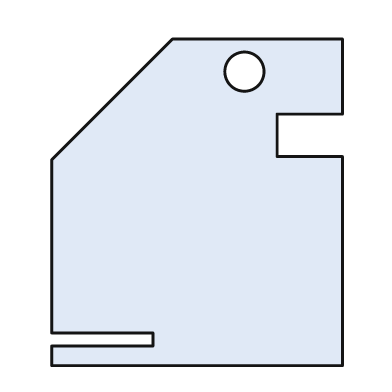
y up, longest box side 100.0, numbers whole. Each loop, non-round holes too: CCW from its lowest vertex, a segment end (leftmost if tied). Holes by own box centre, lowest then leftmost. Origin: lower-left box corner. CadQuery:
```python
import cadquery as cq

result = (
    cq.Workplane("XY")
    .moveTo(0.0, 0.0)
    .lineTo(89.0, 0.0)
    .lineTo(89.0, 64.0)
    .lineTo(69.0, 64.0)
    .lineTo(69.0, 77.0)
    .lineTo(89.0, 77.0)
    .lineTo(89.0, 100.0)
    .lineTo(37.0, 100.0)
    .lineTo(0.0, 63.0)
    .lineTo(0.0, 10.0)
    .lineTo(31.0, 10.0)
    .lineTo(31.0, 6.0)
    .lineTo(0.0, 6.0)
    .close()
    .moveTo(59.0, 90.0)
    .circle(6.0)
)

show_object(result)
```